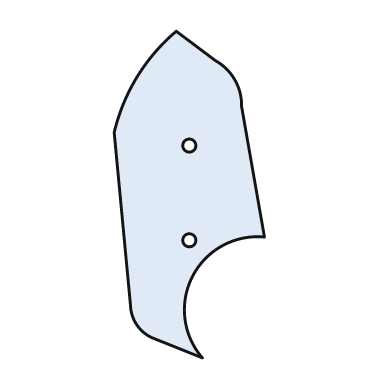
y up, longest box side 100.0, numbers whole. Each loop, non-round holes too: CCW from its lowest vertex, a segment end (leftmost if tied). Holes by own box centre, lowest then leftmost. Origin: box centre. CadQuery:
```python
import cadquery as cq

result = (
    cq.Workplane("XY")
    .moveTo(4.0, -50.0)
    .threePointArc((1.0, -25.0), (23.0, -13.0))
    .lineTo(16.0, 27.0)
    .threePointArc((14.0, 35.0), (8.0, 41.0))
    .lineTo(-4.0, 50.0)
    .threePointArc((-16.0, 36.0), (-23.0, 19.0))
    .lineTo(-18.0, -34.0)
    .threePointArc((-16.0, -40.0), (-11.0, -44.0))
    .close()
    .moveTo(0.0, -14.0)
    .circle(2.0)
    .moveTo(0.0, 15.0)
    .circle(2.0)
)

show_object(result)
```